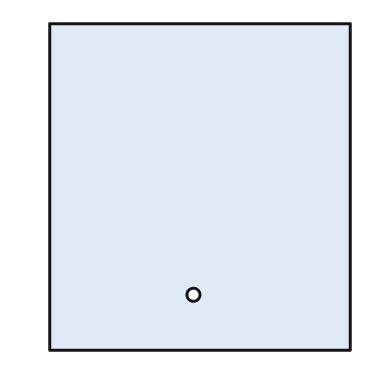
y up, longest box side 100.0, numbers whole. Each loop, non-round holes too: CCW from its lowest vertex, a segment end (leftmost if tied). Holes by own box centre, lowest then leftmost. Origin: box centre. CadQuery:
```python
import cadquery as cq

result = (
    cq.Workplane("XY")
    .moveTo(-46.0, -50.0)
    .lineTo(46.0, -50.0)
    .lineTo(46.0, 50.0)
    .lineTo(-46.0, 50.0)
    .close()
    .moveTo(-2.0, -33.0)
    .circle(2.0)
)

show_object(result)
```